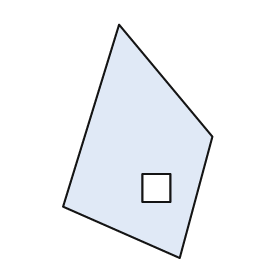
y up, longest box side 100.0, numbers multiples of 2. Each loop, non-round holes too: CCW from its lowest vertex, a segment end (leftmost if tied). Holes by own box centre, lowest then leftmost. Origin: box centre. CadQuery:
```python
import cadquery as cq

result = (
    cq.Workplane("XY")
    .moveTo(18.0, -50.0)
    .lineTo(32.0, 2.0)
    .lineTo(-8.0, 50.0)
    .lineTo(-32.0, -28.0)
    .close()
    .moveTo(2.0, -26.0)
    .lineTo(14.0, -26.0)
    .lineTo(14.0, -14.0)
    .lineTo(2.0, -14.0)
    .close()
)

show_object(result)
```